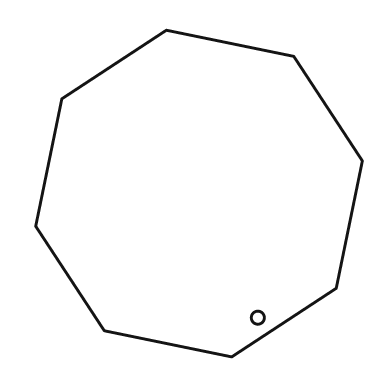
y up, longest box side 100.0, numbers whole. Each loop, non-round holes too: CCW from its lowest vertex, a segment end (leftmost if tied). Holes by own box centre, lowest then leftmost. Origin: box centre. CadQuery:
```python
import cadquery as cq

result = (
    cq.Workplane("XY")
    .moveTo(10.0, -50.0)
    .lineTo(42.0, -29.0)
    .lineTo(50.0, 10.0)
    .lineTo(29.0, 42.0)
    .lineTo(-10.0, 50.0)
    .lineTo(-42.0, 29.0)
    .lineTo(-50.0, -10.0)
    .lineTo(-29.0, -42.0)
    .close()
    .moveTo(18.0, -38.0)
    .circle(2.0)
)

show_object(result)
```